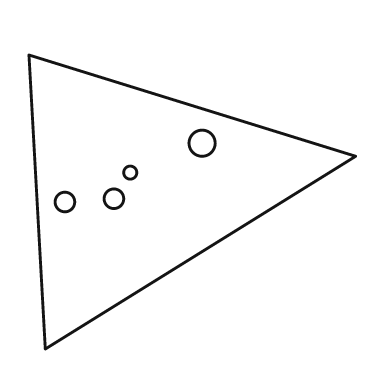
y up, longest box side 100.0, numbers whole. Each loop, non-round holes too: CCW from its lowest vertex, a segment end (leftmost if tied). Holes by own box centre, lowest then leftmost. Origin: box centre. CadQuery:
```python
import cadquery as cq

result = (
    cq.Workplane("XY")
    .moveTo(-45.0, -45.0)
    .lineTo(50.0, 14.0)
    .lineTo(-50.0, 45.0)
    .close()
    .moveTo(-39.0, 0.0)
    .circle(3.0)
    .moveTo(-24.0, 1.0)
    .circle(3.0)
    .moveTo(-19.0, 9.0)
    .circle(2.0)
    .moveTo(3.0, 18.0)
    .circle(4.0)
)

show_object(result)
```